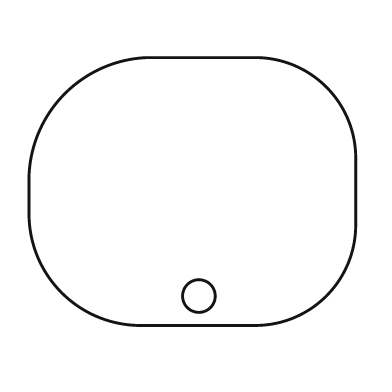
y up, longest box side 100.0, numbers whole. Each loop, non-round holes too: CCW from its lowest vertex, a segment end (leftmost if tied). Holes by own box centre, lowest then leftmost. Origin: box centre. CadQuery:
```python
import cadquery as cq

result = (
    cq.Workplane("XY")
    .moveTo(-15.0, -41.0)
    .lineTo(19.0, -41.0)
    .threePointArc((41.0, -32.0), (50.0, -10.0))
    .lineTo(50.0, 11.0)
    .threePointArc((41.0, 32.0), (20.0, 41.0))
    .lineTo(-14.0, 41.0)
    .threePointArc((-39.0, 30.0), (-50.0, 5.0))
    .lineTo(-50.0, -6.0)
    .threePointArc((-40.0, -31.0), (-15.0, -41.0))
    .close()
    .moveTo(2.0, -32.0)
    .circle(5.0)
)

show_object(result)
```